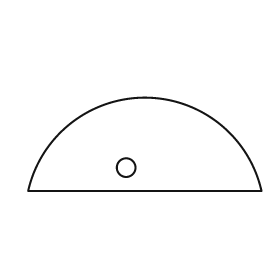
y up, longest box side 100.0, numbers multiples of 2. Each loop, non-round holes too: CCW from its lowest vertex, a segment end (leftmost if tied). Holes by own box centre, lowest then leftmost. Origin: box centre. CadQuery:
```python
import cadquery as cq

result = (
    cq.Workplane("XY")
    .moveTo(-50.0, -20.0)
    .lineTo(50.0, -20.0)
    .threePointArc((0.0, 20.0), (-50.0, -20.0))
    .close()
    .moveTo(-8.0, -10.0)
    .circle(4.0)
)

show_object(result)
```